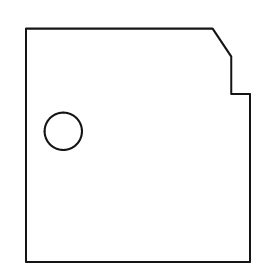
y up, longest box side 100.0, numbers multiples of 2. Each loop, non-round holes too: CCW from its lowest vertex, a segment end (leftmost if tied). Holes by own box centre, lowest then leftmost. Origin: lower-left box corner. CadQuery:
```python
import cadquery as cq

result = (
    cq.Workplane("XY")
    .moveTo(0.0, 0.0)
    .lineTo(96.0, 0.0)
    .lineTo(96.0, 72.0)
    .lineTo(88.0, 72.0)
    .lineTo(88.0, 88.0)
    .lineTo(80.0, 100.0)
    .lineTo(0.0, 100.0)
    .close()
    .moveTo(16.0, 56.0)
    .circle(8.0)
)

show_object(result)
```